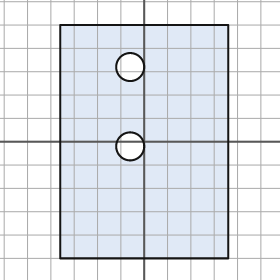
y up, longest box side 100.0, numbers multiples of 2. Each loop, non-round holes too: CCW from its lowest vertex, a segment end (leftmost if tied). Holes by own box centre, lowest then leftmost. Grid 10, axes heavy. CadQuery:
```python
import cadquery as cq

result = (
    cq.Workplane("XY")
    .moveTo(-36.0, -50.0)
    .lineTo(36.0, -50.0)
    .lineTo(36.0, 50.0)
    .lineTo(-36.0, 50.0)
    .close()
    .moveTo(-6.0, -2.0)
    .circle(6.0)
    .moveTo(-6.0, 32.0)
    .circle(6.0)
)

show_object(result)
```